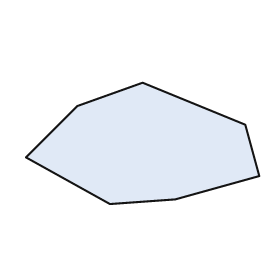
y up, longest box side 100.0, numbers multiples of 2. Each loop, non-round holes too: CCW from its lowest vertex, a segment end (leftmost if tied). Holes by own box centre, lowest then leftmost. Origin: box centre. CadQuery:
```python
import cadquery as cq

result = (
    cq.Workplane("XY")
    .moveTo(-14.0, -26.0)
    .lineTo(14.0, -24.0)
    .lineTo(50.0, -14.0)
    .lineTo(44.0, 8.0)
    .lineTo(0.0, 26.0)
    .lineTo(-28.0, 16.0)
    .lineTo(-50.0, -6.0)
    .close()
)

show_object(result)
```